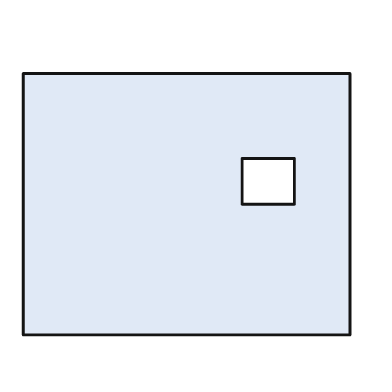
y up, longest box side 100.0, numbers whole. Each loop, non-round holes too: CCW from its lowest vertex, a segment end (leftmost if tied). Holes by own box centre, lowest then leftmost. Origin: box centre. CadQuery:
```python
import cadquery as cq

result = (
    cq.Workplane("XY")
    .moveTo(-50.0, -40.0)
    .lineTo(50.0, -40.0)
    .lineTo(50.0, 40.0)
    .lineTo(-50.0, 40.0)
    .close()
    .moveTo(17.0, 0.0)
    .lineTo(33.0, 0.0)
    .lineTo(33.0, 14.0)
    .lineTo(17.0, 14.0)
    .close()
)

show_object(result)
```